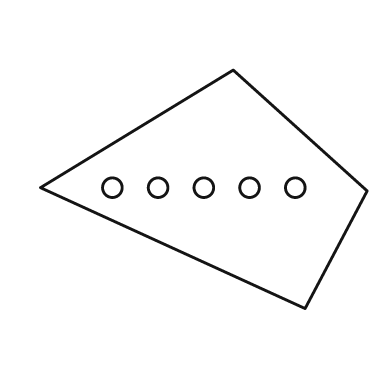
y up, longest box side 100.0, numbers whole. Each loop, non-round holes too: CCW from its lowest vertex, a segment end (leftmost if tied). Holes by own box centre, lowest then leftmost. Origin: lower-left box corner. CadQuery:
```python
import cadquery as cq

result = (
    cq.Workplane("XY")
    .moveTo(81.0, 0.0)
    .lineTo(100.0, 36.0)
    .lineTo(59.0, 73.0)
    .lineTo(0.0, 37.0)
    .close()
    .moveTo(22.0, 37.0)
    .circle(3.0)
    .moveTo(36.0, 37.0)
    .circle(3.0)
    .moveTo(50.0, 37.0)
    .circle(3.0)
    .moveTo(64.0, 37.0)
    .circle(3.0)
    .moveTo(78.0, 37.0)
    .circle(3.0)
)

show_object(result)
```